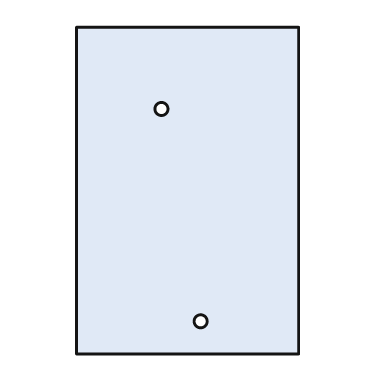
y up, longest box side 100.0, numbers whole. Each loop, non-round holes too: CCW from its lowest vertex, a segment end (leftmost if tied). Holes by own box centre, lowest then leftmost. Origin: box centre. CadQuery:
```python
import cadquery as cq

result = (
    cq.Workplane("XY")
    .moveTo(-34.0, -50.0)
    .lineTo(34.0, -50.0)
    .lineTo(34.0, 50.0)
    .lineTo(-34.0, 50.0)
    .close()
    .moveTo(4.0, -40.0)
    .circle(2.0)
    .moveTo(-8.0, 25.0)
    .circle(2.0)
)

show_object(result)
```